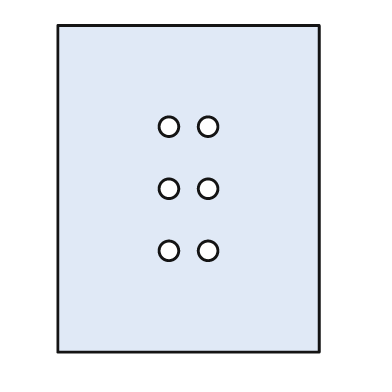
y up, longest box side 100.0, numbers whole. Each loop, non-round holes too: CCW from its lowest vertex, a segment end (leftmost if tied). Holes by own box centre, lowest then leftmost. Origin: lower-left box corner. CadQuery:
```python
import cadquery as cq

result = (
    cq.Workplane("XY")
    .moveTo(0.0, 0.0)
    .lineTo(80.0, 0.0)
    .lineTo(80.0, 100.0)
    .lineTo(0.0, 100.0)
    .close()
    .moveTo(34.0, 31.0)
    .circle(3.0)
    .moveTo(46.0, 31.0)
    .circle(3.0)
    .moveTo(34.0, 50.0)
    .circle(3.0)
    .moveTo(46.0, 50.0)
    .circle(3.0)
    .moveTo(34.0, 69.0)
    .circle(3.0)
    .moveTo(46.0, 69.0)
    .circle(3.0)
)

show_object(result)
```